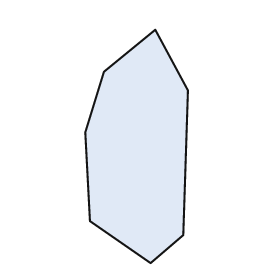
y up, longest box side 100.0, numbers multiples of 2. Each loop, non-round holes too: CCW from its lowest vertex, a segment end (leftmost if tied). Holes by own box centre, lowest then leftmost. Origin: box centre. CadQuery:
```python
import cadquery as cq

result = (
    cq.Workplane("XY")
    .moveTo(6.0, -50.0)
    .lineTo(20.0, -38.0)
    .lineTo(22.0, 24.0)
    .lineTo(8.0, 50.0)
    .lineTo(-14.0, 32.0)
    .lineTo(-22.0, 6.0)
    .lineTo(-20.0, -32.0)
    .close()
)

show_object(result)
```